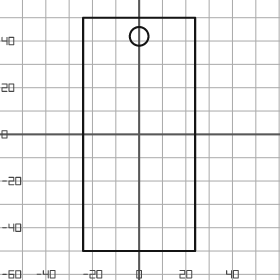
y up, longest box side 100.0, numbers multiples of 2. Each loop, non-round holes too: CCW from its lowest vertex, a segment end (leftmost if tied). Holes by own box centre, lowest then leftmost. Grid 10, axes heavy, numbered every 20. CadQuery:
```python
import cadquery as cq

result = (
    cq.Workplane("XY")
    .moveTo(-24.0, -50.0)
    .lineTo(24.0, -50.0)
    .lineTo(24.0, 50.0)
    .lineTo(-24.0, 50.0)
    .close()
    .moveTo(0.0, 42.0)
    .circle(4.0)
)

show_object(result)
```